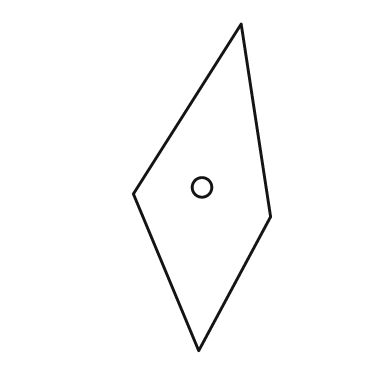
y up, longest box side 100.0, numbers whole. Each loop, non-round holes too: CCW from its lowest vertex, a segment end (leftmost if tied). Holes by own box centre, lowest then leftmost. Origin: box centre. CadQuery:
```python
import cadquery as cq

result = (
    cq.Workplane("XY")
    .moveTo(-1.0, -50.0)
    .lineTo(21.0, -9.0)
    .lineTo(12.0, 50.0)
    .lineTo(-21.0, -2.0)
    .close()
    .moveTo(0.0, 0.0)
    .circle(3.0)
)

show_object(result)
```